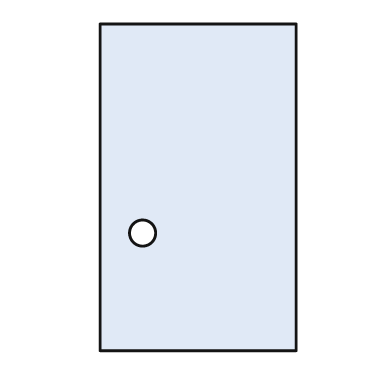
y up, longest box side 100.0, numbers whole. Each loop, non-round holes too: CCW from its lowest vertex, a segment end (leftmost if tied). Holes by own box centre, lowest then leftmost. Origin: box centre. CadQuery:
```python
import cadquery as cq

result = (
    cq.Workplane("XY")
    .moveTo(-30.0, -50.0)
    .lineTo(30.0, -50.0)
    .lineTo(30.0, 50.0)
    .lineTo(-30.0, 50.0)
    .close()
    .moveTo(-17.0, -14.0)
    .circle(4.0)
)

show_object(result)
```